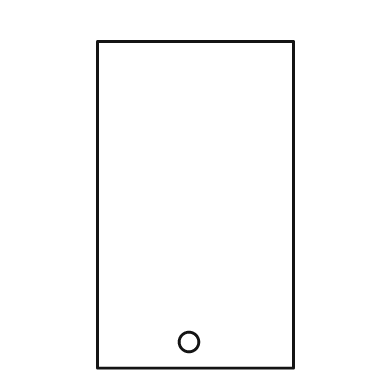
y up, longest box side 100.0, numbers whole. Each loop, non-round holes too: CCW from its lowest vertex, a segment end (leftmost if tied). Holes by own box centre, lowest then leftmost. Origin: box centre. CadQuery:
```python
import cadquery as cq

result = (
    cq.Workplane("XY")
    .moveTo(-30.0, -50.0)
    .lineTo(30.0, -50.0)
    .lineTo(30.0, 50.0)
    .lineTo(-30.0, 50.0)
    .close()
    .moveTo(-2.0, -42.0)
    .circle(3.0)
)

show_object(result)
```